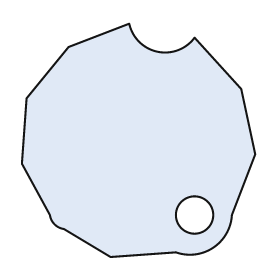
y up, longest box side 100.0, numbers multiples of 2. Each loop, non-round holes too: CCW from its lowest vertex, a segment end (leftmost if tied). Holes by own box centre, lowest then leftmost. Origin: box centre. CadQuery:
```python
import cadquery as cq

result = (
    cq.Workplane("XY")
    .moveTo(-12.0, -50.0)
    .lineTo(16.0, -48.0)
    .threePointArc((32.0, -46.0), (40.0, -32.0))
    .lineTo(50.0, -6.0)
    .lineTo(44.0, 22.0)
    .lineTo(24.0, 44.0)
    .threePointArc((8.0, 38.0), (-4.0, 50.0))
    .lineTo(-30.0, 40.0)
    .lineTo(-48.0, 18.0)
    .lineTo(-50.0, -10.0)
    .lineTo(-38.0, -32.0)
    .threePointArc((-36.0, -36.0), (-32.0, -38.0))
    .close()
    .moveTo(24.0, -32.0)
    .circle(8.0)
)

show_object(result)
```